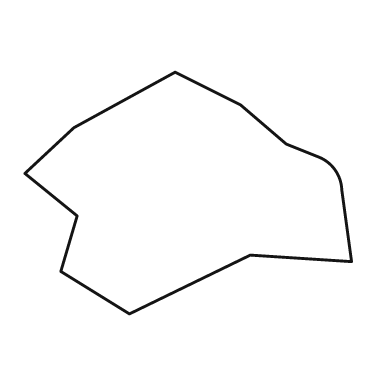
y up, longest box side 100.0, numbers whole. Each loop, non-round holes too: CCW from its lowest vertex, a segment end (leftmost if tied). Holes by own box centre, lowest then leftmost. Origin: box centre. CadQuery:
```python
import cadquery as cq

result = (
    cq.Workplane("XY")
    .moveTo(-18.0, -37.0)
    .lineTo(19.0, -19.0)
    .lineTo(50.0, -21.0)
    .lineTo(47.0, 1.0)
    .threePointArc((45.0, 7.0), (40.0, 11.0))
    .lineTo(30.0, 15.0)
    .lineTo(16.0, 27.0)
    .lineTo(-4.0, 37.0)
    .lineTo(-35.0, 20.0)
    .lineTo(-50.0, 6.0)
    .lineTo(-34.0, -7.0)
    .lineTo(-39.0, -24.0)
    .close()
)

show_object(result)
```